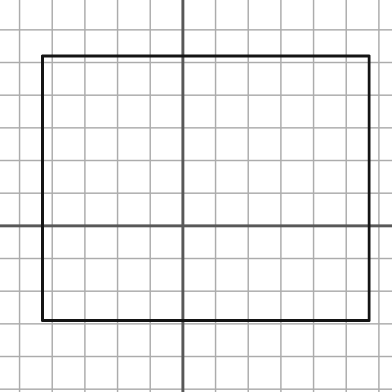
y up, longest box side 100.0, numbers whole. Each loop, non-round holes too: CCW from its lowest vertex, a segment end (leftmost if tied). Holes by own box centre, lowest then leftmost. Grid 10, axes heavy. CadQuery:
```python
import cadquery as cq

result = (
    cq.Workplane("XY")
    .moveTo(-43.0, -29.0)
    .lineTo(57.0, -29.0)
    .lineTo(57.0, 52.0)
    .lineTo(-43.0, 52.0)
    .close()
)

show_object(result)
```